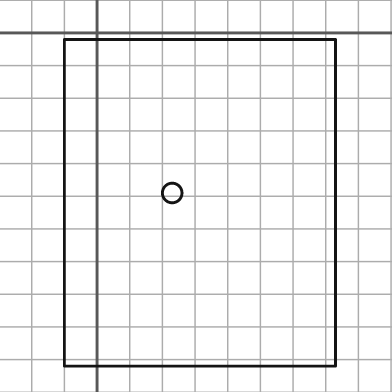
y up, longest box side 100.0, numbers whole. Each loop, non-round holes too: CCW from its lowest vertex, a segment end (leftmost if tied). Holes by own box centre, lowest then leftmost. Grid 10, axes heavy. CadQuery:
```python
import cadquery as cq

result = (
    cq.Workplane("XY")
    .moveTo(-10.0, -102.0)
    .lineTo(73.0, -102.0)
    .lineTo(73.0, -2.0)
    .lineTo(-10.0, -2.0)
    .close()
    .moveTo(23.0, -49.0)
    .circle(3.0)
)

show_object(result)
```